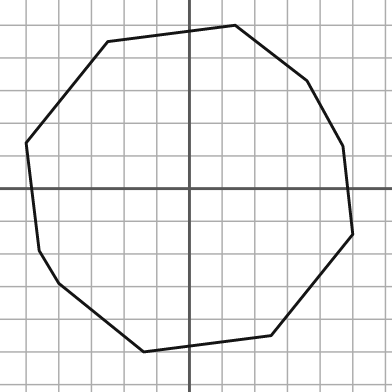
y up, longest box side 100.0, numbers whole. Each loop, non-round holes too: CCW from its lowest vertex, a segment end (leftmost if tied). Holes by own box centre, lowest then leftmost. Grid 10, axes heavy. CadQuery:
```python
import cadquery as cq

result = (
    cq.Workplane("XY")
    .moveTo(-14.0, -50.0)
    .lineTo(25.0, -45.0)
    .lineTo(50.0, -14.0)
    .lineTo(47.0, 13.0)
    .lineTo(36.0, 33.0)
    .lineTo(14.0, 50.0)
    .lineTo(-25.0, 45.0)
    .lineTo(-50.0, 14.0)
    .lineTo(-46.0, -19.0)
    .lineTo(-40.0, -29.0)
    .close()
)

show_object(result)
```